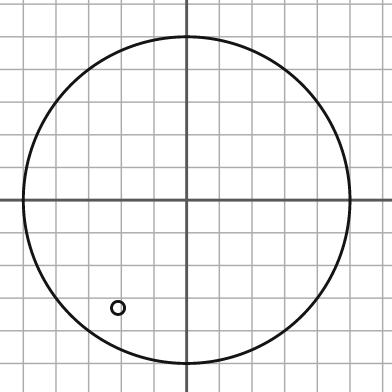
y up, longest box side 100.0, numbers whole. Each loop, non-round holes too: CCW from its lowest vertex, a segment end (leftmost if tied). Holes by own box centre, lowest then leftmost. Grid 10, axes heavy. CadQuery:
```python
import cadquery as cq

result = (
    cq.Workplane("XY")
    .moveTo(0.0, 0.0)
    .circle(50.0)
    .moveTo(-21.0, -33.0)
    .circle(2.0)
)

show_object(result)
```